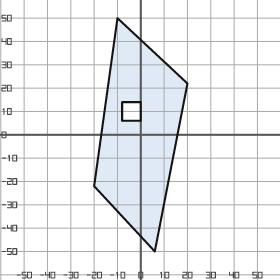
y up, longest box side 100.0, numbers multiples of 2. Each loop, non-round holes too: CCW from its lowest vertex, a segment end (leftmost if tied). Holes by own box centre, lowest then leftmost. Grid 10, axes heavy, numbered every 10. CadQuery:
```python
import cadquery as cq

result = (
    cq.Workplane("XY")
    .moveTo(6.0, -50.0)
    .lineTo(20.0, 22.0)
    .lineTo(-10.0, 50.0)
    .lineTo(-20.0, -22.0)
    .close()
    .moveTo(-8.0, 6.0)
    .lineTo(0.0, 6.0)
    .lineTo(0.0, 14.0)
    .lineTo(-8.0, 14.0)
    .close()
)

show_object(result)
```